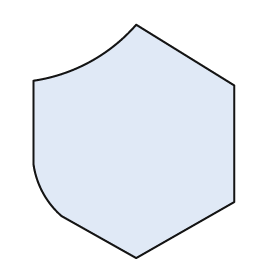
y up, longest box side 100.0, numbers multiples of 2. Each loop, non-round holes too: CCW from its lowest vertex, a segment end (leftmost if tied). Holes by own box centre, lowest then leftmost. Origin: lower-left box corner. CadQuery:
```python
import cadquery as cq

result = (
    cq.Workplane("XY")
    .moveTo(44.0, 0.0)
    .lineTo(86.0, 24.0)
    .lineTo(86.0, 74.0)
    .lineTo(44.0, 100.0)
    .threePointArc((24.0, 84.0), (0.0, 76.0))
    .lineTo(0.0, 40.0)
    .threePointArc((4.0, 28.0), (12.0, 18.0))
    .close()
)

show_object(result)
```